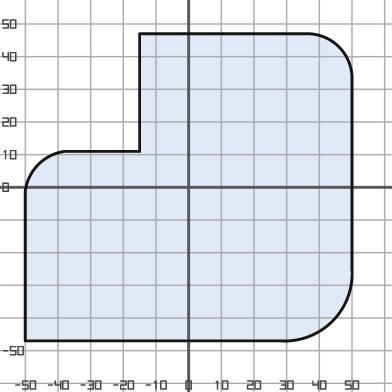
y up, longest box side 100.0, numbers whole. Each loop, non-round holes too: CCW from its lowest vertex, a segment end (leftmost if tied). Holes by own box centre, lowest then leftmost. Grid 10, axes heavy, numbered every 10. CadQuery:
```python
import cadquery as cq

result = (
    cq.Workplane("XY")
    .moveTo(-50.0, -47.0)
    .lineTo(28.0, -47.0)
    .threePointArc((44.0, -41.0), (50.0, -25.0))
    .lineTo(50.0, 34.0)
    .threePointArc((46.0, 43.0), (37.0, 47.0))
    .lineTo(-15.0, 47.0)
    .lineTo(-15.0, 11.0)
    .lineTo(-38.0, 11.0)
    .threePointArc((-46.0, 7.0), (-50.0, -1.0))
    .close()
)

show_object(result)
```